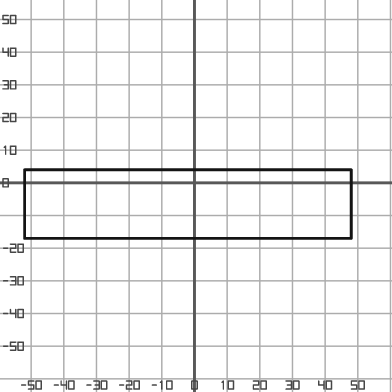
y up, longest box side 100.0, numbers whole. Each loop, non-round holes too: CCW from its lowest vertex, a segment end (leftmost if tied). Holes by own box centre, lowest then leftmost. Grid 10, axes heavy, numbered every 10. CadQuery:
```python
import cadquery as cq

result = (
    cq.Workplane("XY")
    .moveTo(-52.0, -17.0)
    .lineTo(48.0, -17.0)
    .lineTo(48.0, 4.0)
    .lineTo(-52.0, 4.0)
    .close()
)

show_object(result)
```